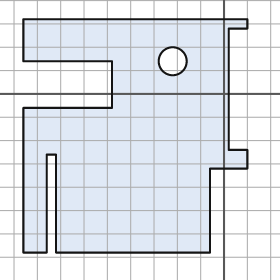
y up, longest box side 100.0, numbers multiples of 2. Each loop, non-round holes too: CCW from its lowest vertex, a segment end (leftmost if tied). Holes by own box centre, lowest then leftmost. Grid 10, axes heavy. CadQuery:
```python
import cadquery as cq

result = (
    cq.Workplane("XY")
    .moveTo(-86.0, -68.0)
    .lineTo(-76.0, -68.0)
    .lineTo(-76.0, -26.0)
    .lineTo(-72.0, -26.0)
    .lineTo(-72.0, -68.0)
    .lineTo(-6.0, -68.0)
    .lineTo(-6.0, -32.0)
    .lineTo(10.0, -32.0)
    .lineTo(10.0, -24.0)
    .lineTo(2.0, -24.0)
    .lineTo(2.0, 28.0)
    .lineTo(10.0, 28.0)
    .lineTo(10.0, 32.0)
    .lineTo(-86.0, 32.0)
    .lineTo(-86.0, 14.0)
    .lineTo(-48.0, 14.0)
    .lineTo(-48.0, -6.0)
    .lineTo(-86.0, -6.0)
    .close()
    .moveTo(-22.0, 14.0)
    .circle(6.0)
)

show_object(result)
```